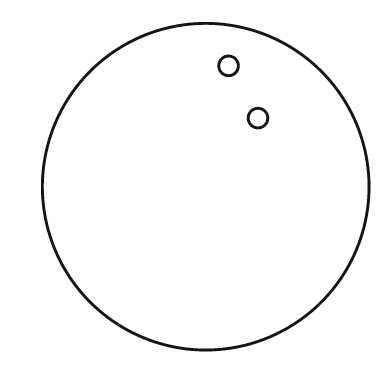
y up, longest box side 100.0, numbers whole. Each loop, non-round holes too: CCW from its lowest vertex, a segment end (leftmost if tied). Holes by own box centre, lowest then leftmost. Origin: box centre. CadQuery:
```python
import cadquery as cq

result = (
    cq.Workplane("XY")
    .moveTo(0.0, 0.0)
    .circle(50.0)
    .moveTo(16.0, 21.0)
    .circle(3.0)
    .moveTo(7.0, 37.0)
    .circle(3.0)
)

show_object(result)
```